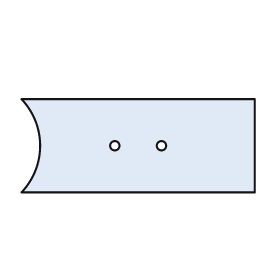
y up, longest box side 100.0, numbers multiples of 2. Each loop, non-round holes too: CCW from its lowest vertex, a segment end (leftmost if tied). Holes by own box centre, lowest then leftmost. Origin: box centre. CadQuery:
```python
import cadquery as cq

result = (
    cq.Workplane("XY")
    .moveTo(-50.0, -20.0)
    .lineTo(50.0, -20.0)
    .lineTo(50.0, 20.0)
    .lineTo(-50.0, 20.0)
    .threePointArc((-42.0, 0.0), (-50.0, -20.0))
    .close()
    .moveTo(-10.0, 0.0)
    .circle(2.0)
    .moveTo(10.0, 0.0)
    .circle(2.0)
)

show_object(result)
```